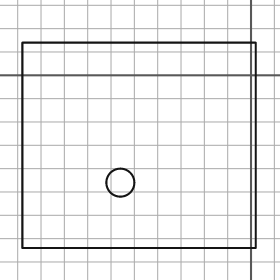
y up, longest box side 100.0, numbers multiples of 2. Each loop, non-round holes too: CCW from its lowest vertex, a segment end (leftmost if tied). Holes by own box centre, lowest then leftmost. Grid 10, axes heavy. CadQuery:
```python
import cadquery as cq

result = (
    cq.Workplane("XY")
    .moveTo(-98.0, -74.0)
    .lineTo(2.0, -74.0)
    .lineTo(2.0, 14.0)
    .lineTo(-98.0, 14.0)
    .close()
    .moveTo(-56.0, -46.0)
    .circle(6.0)
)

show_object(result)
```